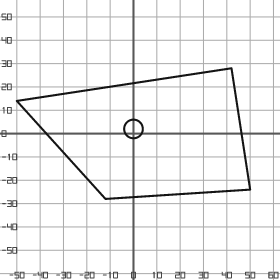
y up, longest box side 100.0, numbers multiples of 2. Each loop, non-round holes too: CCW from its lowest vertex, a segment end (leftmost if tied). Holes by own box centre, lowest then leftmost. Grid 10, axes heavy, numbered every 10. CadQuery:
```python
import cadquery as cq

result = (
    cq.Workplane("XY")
    .moveTo(-12.0, -28.0)
    .lineTo(50.0, -24.0)
    .lineTo(42.0, 28.0)
    .lineTo(-50.0, 14.0)
    .close()
    .moveTo(0.0, 2.0)
    .circle(4.0)
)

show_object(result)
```